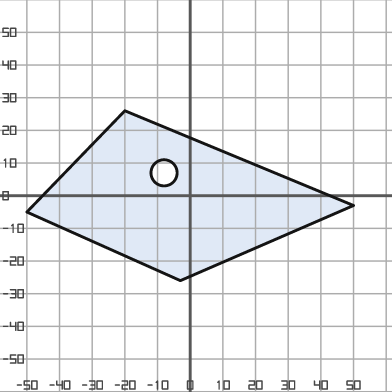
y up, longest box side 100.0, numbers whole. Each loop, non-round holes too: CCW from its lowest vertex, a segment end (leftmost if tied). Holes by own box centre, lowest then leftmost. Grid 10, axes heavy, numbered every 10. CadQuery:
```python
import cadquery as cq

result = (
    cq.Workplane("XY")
    .moveTo(-3.0, -26.0)
    .lineTo(50.0, -3.0)
    .lineTo(-20.0, 26.0)
    .lineTo(-50.0, -5.0)
    .close()
    .moveTo(-8.0, 7.0)
    .circle(4.0)
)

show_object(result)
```